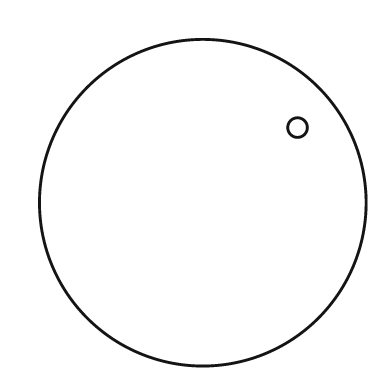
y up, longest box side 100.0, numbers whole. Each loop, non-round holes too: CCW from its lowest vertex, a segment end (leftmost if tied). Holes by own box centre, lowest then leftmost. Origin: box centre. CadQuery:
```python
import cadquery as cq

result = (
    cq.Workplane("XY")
    .moveTo(0.0, 0.0)
    .circle(50.0)
    .moveTo(29.0, 23.0)
    .circle(3.0)
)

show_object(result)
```